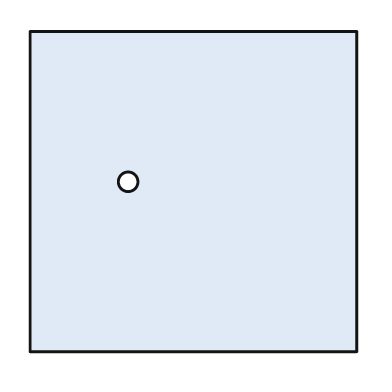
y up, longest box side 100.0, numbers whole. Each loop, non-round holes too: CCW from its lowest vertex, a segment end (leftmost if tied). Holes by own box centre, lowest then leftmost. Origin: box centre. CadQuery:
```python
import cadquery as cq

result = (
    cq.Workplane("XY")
    .moveTo(-50.0, -49.0)
    .lineTo(50.0, -49.0)
    .lineTo(50.0, 49.0)
    .lineTo(-50.0, 49.0)
    .close()
    .moveTo(-20.0, 3.0)
    .circle(3.0)
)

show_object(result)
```